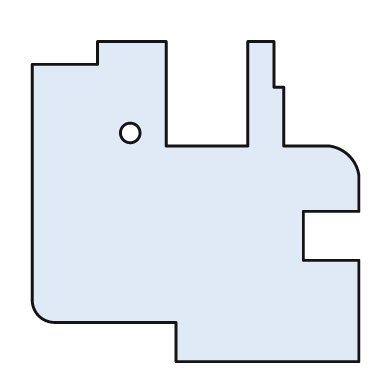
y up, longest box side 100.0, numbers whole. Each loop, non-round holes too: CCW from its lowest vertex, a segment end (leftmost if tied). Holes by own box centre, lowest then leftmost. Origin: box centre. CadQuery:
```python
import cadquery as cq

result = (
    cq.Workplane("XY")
    .moveTo(-6.0, -49.0)
    .lineTo(50.0, -49.0)
    .lineTo(50.0, -18.0)
    .lineTo(33.0, -18.0)
    .lineTo(33.0, -3.0)
    .lineTo(50.0, -3.0)
    .lineTo(50.0, 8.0)
    .threePointArc((47.0, 14.0), (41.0, 17.0))
    .lineTo(27.0, 17.0)
    .lineTo(27.0, 35.0)
    .lineTo(24.0, 35.0)
    .lineTo(24.0, 49.0)
    .lineTo(16.0, 49.0)
    .lineTo(16.0, 17.0)
    .lineTo(-9.0, 17.0)
    .lineTo(-9.0, 49.0)
    .lineTo(-30.0, 49.0)
    .lineTo(-30.0, 42.0)
    .lineTo(-50.0, 42.0)
    .lineTo(-50.0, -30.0)
    .threePointArc((-48.0, -35.0), (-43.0, -37.0))
    .lineTo(-6.0, -37.0)
    .close()
    .moveTo(-20.0, 21.0)
    .circle(3.0)
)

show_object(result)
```